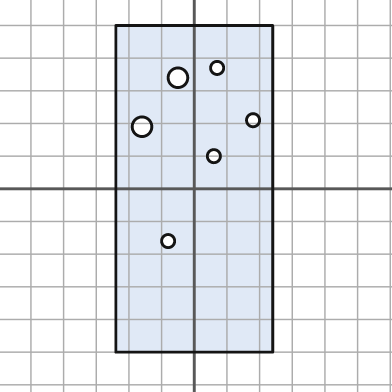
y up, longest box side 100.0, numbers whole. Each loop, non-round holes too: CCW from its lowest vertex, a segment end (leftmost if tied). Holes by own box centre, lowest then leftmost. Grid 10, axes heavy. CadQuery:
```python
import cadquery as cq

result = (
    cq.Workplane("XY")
    .moveTo(-24.0, -50.0)
    .lineTo(24.0, -50.0)
    .lineTo(24.0, 50.0)
    .lineTo(-24.0, 50.0)
    .close()
    .moveTo(-8.0, -16.0)
    .circle(2.0)
    .moveTo(6.0, 10.0)
    .circle(2.0)
    .moveTo(-16.0, 19.0)
    .circle(3.0)
    .moveTo(18.0, 21.0)
    .circle(2.0)
    .moveTo(-5.0, 34.0)
    .circle(3.0)
    .moveTo(7.0, 37.0)
    .circle(2.0)
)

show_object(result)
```